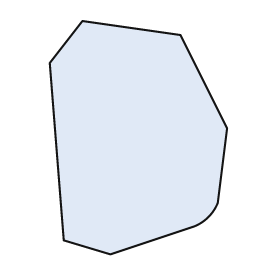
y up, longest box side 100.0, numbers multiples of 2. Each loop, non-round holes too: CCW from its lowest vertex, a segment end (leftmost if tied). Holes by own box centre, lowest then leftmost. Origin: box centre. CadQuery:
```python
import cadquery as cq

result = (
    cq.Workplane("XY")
    .moveTo(-12.0, -50.0)
    .lineTo(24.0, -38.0)
    .threePointArc((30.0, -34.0), (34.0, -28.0))
    .lineTo(38.0, 4.0)
    .lineTo(18.0, 44.0)
    .lineTo(-24.0, 50.0)
    .lineTo(-38.0, 32.0)
    .lineTo(-32.0, -44.0)
    .close()
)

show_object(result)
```